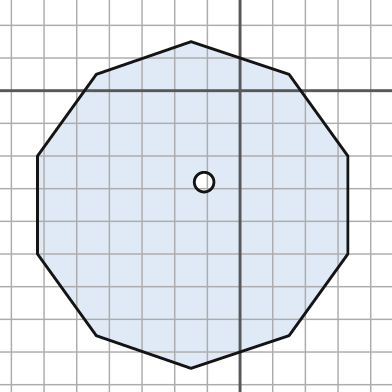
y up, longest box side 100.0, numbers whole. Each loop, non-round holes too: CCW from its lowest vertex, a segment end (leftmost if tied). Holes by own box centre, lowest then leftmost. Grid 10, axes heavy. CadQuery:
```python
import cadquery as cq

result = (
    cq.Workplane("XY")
    .moveTo(-15.0, -85.0)
    .lineTo(15.0, -75.0)
    .lineTo(33.0, -50.0)
    .lineTo(33.0, -20.0)
    .lineTo(15.0, 5.0)
    .lineTo(-15.0, 15.0)
    .lineTo(-44.0, 5.0)
    .lineTo(-62.0, -20.0)
    .lineTo(-62.0, -50.0)
    .lineTo(-44.0, -75.0)
    .close()
    .moveTo(-11.0, -28.0)
    .circle(3.0)
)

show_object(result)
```